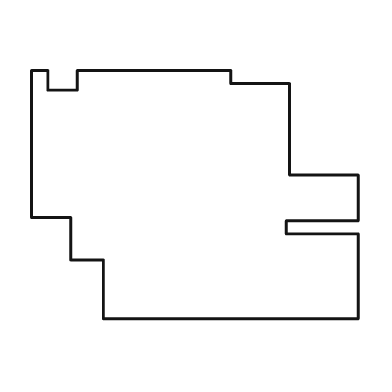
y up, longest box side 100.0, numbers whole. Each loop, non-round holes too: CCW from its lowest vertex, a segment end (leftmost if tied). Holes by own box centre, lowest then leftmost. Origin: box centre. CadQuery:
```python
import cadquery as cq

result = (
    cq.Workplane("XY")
    .moveTo(-28.0, -38.0)
    .lineTo(50.0, -38.0)
    .lineTo(50.0, -12.0)
    .lineTo(28.0, -12.0)
    .lineTo(28.0, -8.0)
    .lineTo(50.0, -8.0)
    .lineTo(50.0, 6.0)
    .lineTo(29.0, 6.0)
    .lineTo(29.0, 34.0)
    .lineTo(11.0, 34.0)
    .lineTo(11.0, 38.0)
    .lineTo(-36.0, 38.0)
    .lineTo(-36.0, 32.0)
    .lineTo(-45.0, 32.0)
    .lineTo(-45.0, 38.0)
    .lineTo(-50.0, 38.0)
    .lineTo(-50.0, -7.0)
    .lineTo(-38.0, -7.0)
    .lineTo(-38.0, -20.0)
    .lineTo(-28.0, -20.0)
    .close()
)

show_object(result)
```